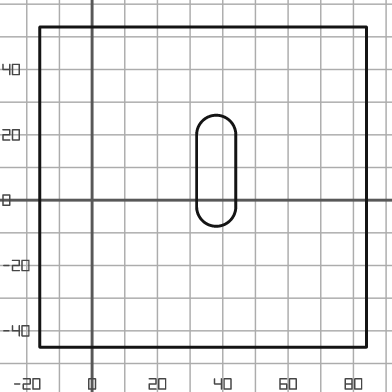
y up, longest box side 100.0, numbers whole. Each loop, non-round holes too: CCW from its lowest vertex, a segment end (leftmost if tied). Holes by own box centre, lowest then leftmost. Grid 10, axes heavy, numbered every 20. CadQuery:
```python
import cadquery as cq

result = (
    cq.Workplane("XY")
    .moveTo(-16.0, -45.0)
    .lineTo(84.0, -45.0)
    .lineTo(84.0, 53.0)
    .lineTo(-16.0, 53.0)
    .close()
    .moveTo(32.0, -2.0)
    .threePointArc((38.0, -8.0), (44.0, -2.0))
    .lineTo(44.0, 20.0)
    .threePointArc((38.0, 26.0), (32.0, 20.0))
    .close()
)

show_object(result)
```